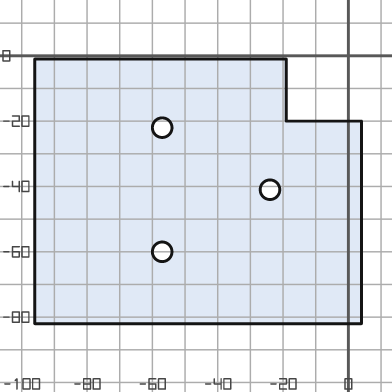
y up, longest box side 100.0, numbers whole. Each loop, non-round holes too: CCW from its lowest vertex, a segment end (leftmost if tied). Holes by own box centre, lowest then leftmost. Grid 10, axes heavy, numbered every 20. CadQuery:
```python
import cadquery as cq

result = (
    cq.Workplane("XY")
    .moveTo(-96.0, -82.0)
    .lineTo(4.0, -82.0)
    .lineTo(4.0, -20.0)
    .lineTo(-19.0, -20.0)
    .lineTo(-19.0, -1.0)
    .lineTo(-96.0, -1.0)
    .close()
    .moveTo(-57.0, -60.0)
    .circle(3.0)
    .moveTo(-24.0, -41.0)
    .circle(3.0)
    .moveTo(-57.0, -22.0)
    .circle(3.0)
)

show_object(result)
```